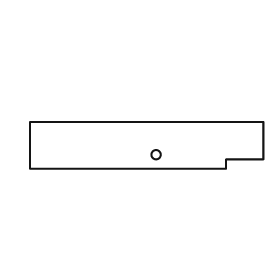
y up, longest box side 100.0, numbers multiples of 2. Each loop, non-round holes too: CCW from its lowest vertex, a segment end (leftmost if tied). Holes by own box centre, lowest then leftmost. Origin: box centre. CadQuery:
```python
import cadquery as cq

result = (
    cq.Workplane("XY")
    .moveTo(-50.0, -10.0)
    .lineTo(34.0, -10.0)
    .lineTo(34.0, -6.0)
    .lineTo(50.0, -6.0)
    .lineTo(50.0, 10.0)
    .lineTo(-50.0, 10.0)
    .close()
    .moveTo(4.0, -4.0)
    .circle(2.0)
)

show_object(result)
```